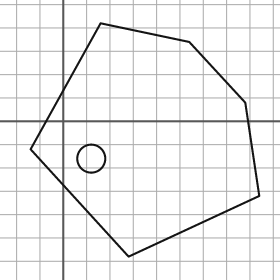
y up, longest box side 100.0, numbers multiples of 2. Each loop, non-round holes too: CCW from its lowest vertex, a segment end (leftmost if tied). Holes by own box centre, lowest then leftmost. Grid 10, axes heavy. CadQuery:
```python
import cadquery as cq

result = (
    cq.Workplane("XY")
    .moveTo(28.0, -58.0)
    .lineTo(84.0, -32.0)
    .lineTo(78.0, 8.0)
    .lineTo(54.0, 34.0)
    .lineTo(16.0, 42.0)
    .lineTo(-14.0, -12.0)
    .close()
    .moveTo(12.0, -16.0)
    .circle(6.0)
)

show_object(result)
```